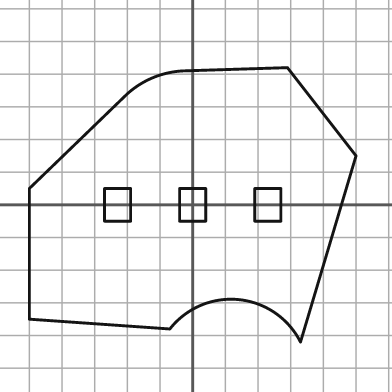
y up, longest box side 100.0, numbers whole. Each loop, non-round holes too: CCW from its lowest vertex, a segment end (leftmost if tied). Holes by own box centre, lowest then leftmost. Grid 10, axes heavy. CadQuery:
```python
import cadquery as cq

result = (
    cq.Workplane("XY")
    .moveTo(33.0, -42.0)
    .lineTo(50.0, 15.0)
    .lineTo(29.0, 42.0)
    .lineTo(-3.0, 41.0)
    .threePointArc((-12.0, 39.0), (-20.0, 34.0))
    .lineTo(-50.0, 5.0)
    .lineTo(-50.0, -35.0)
    .lineTo(-7.0, -38.0)
    .threePointArc((14.0, -29.0), (33.0, -42.0))
    .close()
    .moveTo(-27.0, -5.0)
    .lineTo(-19.0, -5.0)
    .lineTo(-19.0, 5.0)
    .lineTo(-27.0, 5.0)
    .close()
    .moveTo(-4.0, -5.0)
    .lineTo(4.0, -5.0)
    .lineTo(4.0, 5.0)
    .lineTo(-4.0, 5.0)
    .close()
    .moveTo(19.0, -5.0)
    .lineTo(27.0, -5.0)
    .lineTo(27.0, 5.0)
    .lineTo(19.0, 5.0)
    .close()
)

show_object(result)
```